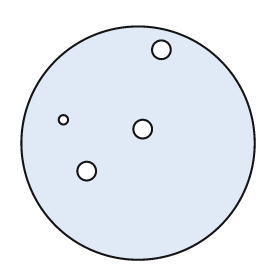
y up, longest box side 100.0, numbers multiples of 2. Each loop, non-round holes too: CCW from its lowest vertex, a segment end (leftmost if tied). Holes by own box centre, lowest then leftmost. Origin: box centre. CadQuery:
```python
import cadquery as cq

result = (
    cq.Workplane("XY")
    .moveTo(0.0, 0.0)
    .circle(50.0)
    .moveTo(-22.0, -12.0)
    .circle(4.0)
    .moveTo(2.0, 6.0)
    .circle(4.0)
    .moveTo(-32.0, 10.0)
    .circle(2.0)
    .moveTo(10.0, 40.0)
    .circle(4.0)
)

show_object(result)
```